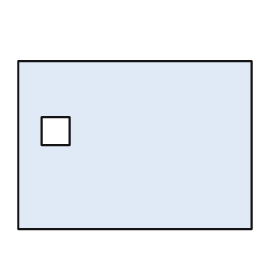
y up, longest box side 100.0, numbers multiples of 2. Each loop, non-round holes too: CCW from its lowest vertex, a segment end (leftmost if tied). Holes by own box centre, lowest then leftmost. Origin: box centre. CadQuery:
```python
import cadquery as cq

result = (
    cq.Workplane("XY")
    .moveTo(-50.0, -36.0)
    .lineTo(50.0, -36.0)
    .lineTo(50.0, 36.0)
    .lineTo(-50.0, 36.0)
    .close()
    .moveTo(-40.0, 0.0)
    .lineTo(-28.0, 0.0)
    .lineTo(-28.0, 12.0)
    .lineTo(-40.0, 12.0)
    .close()
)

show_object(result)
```